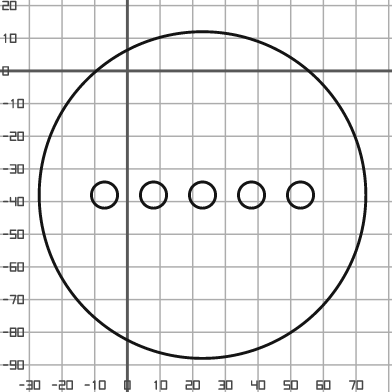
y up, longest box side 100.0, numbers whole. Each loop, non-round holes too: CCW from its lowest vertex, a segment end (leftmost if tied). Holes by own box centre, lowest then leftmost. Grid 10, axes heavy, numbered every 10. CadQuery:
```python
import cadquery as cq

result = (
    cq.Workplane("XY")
    .moveTo(23.0, -38.0)
    .circle(50.0)
    .moveTo(-7.0, -38.0)
    .circle(4.0)
    .moveTo(8.0, -38.0)
    .circle(4.0)
    .moveTo(23.0, -38.0)
    .circle(4.0)
    .moveTo(38.0, -38.0)
    .circle(4.0)
    .moveTo(53.0, -38.0)
    .circle(4.0)
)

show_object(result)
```